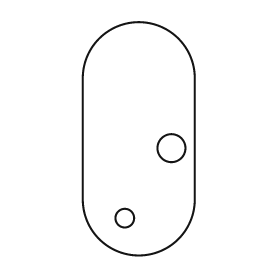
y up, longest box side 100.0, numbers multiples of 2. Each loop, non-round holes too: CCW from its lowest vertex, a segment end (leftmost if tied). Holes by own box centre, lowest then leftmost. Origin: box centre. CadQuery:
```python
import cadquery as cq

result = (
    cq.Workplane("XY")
    .moveTo(-24.0, -26.0)
    .threePointArc((0.0, -50.0), (24.0, -26.0))
    .lineTo(24.0, 26.0)
    .threePointArc((0.0, 50.0), (-24.0, 26.0))
    .close()
    .moveTo(-6.0, -34.0)
    .circle(4.0)
    .moveTo(14.0, -4.0)
    .circle(6.0)
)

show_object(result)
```